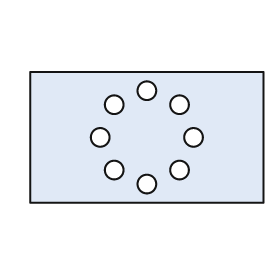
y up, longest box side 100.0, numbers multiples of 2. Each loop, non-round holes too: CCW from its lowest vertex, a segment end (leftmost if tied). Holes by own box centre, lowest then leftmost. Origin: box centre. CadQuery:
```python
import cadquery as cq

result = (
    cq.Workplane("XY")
    .moveTo(-50.0, -28.0)
    .lineTo(50.0, -28.0)
    .lineTo(50.0, 28.0)
    .lineTo(-50.0, 28.0)
    .close()
    .moveTo(0.0, -20.0)
    .circle(4.0)
    .moveTo(-14.0, -14.0)
    .circle(4.0)
    .moveTo(14.0, -14.0)
    .circle(4.0)
    .moveTo(-20.0, 0.0)
    .circle(4.0)
    .moveTo(20.0, 0.0)
    .circle(4.0)
    .moveTo(-14.0, 14.0)
    .circle(4.0)
    .moveTo(14.0, 14.0)
    .circle(4.0)
    .moveTo(0.0, 20.0)
    .circle(4.0)
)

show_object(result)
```